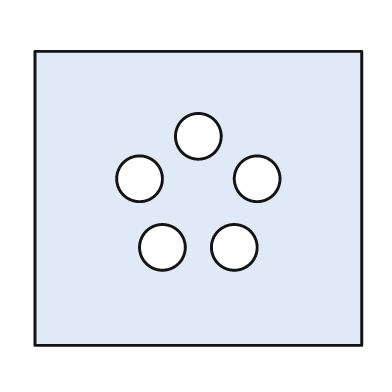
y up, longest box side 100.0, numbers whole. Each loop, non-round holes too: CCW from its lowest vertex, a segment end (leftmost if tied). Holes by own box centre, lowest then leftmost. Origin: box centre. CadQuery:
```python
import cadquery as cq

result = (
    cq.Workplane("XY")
    .moveTo(-50.0, -45.0)
    .lineTo(50.0, -45.0)
    .lineTo(50.0, 45.0)
    .lineTo(-50.0, 45.0)
    .close()
    .moveTo(-11.0, -15.0)
    .circle(7.0)
    .moveTo(11.0, -15.0)
    .circle(7.0)
    .moveTo(-18.0, 6.0)
    .circle(7.0)
    .moveTo(18.0, 6.0)
    .circle(7.0)
    .moveTo(0.0, 19.0)
    .circle(7.0)
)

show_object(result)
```